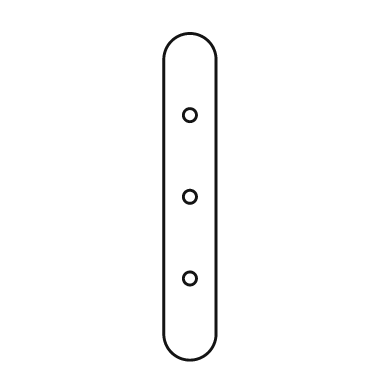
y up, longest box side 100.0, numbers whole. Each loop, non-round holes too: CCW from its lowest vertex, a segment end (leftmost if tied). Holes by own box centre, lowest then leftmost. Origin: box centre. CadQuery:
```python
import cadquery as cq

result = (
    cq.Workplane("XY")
    .moveTo(-8.0, -42.0)
    .threePointArc((0.0, -50.0), (8.0, -42.0))
    .lineTo(8.0, 42.0)
    .threePointArc((0.0, 50.0), (-8.0, 42.0))
    .close()
    .moveTo(0.0, -25.0)
    .circle(2.0)
    .moveTo(0.0, 0.0)
    .circle(2.0)
    .moveTo(0.0, 25.0)
    .circle(2.0)
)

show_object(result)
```